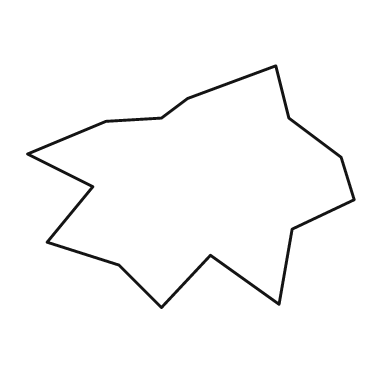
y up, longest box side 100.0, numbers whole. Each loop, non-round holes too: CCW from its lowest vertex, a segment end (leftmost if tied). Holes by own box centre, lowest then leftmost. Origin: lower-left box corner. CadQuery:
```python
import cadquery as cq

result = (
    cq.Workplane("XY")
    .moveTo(41.0, 0.0)
    .lineTo(56.0, 16.0)
    .lineTo(77.0, 1.0)
    .lineTo(81.0, 24.0)
    .lineTo(100.0, 33.0)
    .lineTo(96.0, 46.0)
    .lineTo(80.0, 58.0)
    .lineTo(76.0, 74.0)
    .lineTo(49.0, 64.0)
    .lineTo(41.0, 58.0)
    .lineTo(24.0, 57.0)
    .lineTo(0.0, 47.0)
    .lineTo(20.0, 37.0)
    .lineTo(6.0, 20.0)
    .lineTo(28.0, 13.0)
    .close()
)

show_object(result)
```